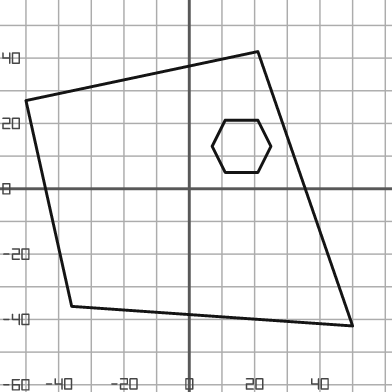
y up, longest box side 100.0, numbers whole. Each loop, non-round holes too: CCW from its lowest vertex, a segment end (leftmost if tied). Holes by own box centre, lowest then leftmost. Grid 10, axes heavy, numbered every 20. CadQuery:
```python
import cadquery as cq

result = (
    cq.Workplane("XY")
    .moveTo(50.0, -42.0)
    .lineTo(21.0, 42.0)
    .lineTo(-50.0, 27.0)
    .lineTo(-36.0, -36.0)
    .close()
    .moveTo(11.0, 5.0)
    .lineTo(21.0, 5.0)
    .lineTo(25.0, 13.0)
    .lineTo(21.0, 21.0)
    .lineTo(11.0, 21.0)
    .lineTo(7.0, 13.0)
    .close()
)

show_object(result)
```